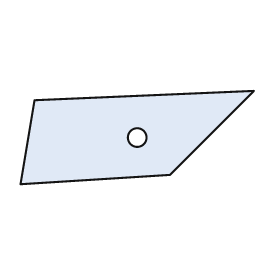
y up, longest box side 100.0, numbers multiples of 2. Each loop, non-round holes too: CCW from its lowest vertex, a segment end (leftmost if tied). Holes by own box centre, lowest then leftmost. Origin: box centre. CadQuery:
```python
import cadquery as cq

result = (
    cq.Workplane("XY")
    .moveTo(-50.0, -20.0)
    .lineTo(14.0, -16.0)
    .lineTo(50.0, 20.0)
    .lineTo(-44.0, 16.0)
    .close()
    .moveTo(0.0, 0.0)
    .circle(4.0)
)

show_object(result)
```